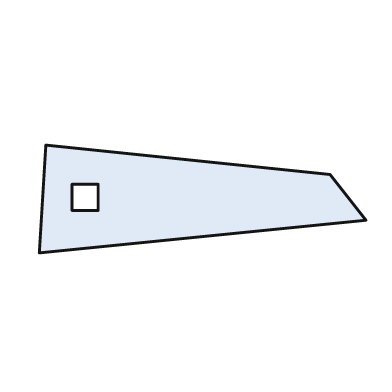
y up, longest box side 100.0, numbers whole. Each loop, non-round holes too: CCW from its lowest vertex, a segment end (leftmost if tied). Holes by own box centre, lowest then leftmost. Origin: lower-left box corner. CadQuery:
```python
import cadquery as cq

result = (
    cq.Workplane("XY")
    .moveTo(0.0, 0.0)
    .lineTo(100.0, 10.0)
    .lineTo(89.0, 24.0)
    .lineTo(2.0, 33.0)
    .close()
    .moveTo(10.0, 13.0)
    .lineTo(18.0, 13.0)
    .lineTo(18.0, 21.0)
    .lineTo(10.0, 21.0)
    .close()
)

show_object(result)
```